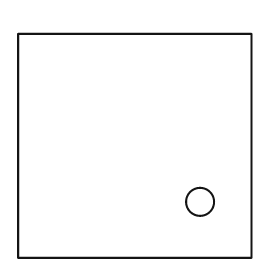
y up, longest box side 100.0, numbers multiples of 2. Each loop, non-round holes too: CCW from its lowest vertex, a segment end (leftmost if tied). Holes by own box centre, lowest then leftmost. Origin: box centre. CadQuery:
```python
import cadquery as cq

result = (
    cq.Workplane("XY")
    .moveTo(-50.0, -48.0)
    .lineTo(50.0, -48.0)
    .lineTo(50.0, 48.0)
    .lineTo(-50.0, 48.0)
    .close()
    .moveTo(28.0, -24.0)
    .circle(6.0)
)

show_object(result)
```